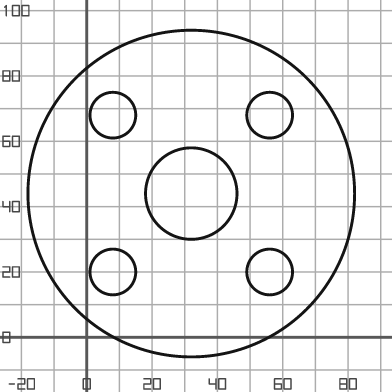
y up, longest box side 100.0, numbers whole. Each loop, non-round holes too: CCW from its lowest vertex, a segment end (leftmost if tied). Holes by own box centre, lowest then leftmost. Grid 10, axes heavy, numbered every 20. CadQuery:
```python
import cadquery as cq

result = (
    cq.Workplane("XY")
    .moveTo(32.0, 44.0)
    .circle(50.0)
    .moveTo(8.0, 20.0)
    .circle(7.0)
    .moveTo(56.0, 20.0)
    .circle(7.0)
    .moveTo(32.0, 44.0)
    .circle(14.0)
    .moveTo(8.0, 68.0)
    .circle(7.0)
    .moveTo(56.0, 68.0)
    .circle(7.0)
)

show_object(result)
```